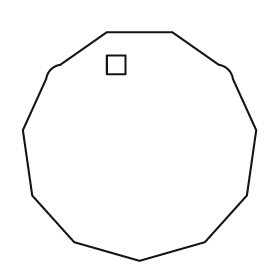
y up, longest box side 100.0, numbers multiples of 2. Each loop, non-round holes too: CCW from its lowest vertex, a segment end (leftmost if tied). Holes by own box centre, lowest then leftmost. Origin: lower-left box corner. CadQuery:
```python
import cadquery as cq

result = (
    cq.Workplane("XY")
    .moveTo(50.0, 0.0)
    .lineTo(78.0, 8.0)
    .lineTo(96.0, 28.0)
    .lineTo(100.0, 56.0)
    .lineTo(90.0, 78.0)
    .threePointArc((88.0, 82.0), (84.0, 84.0))
    .lineTo(64.0, 98.0)
    .lineTo(36.0, 98.0)
    .lineTo(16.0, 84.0)
    .threePointArc((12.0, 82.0), (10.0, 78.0))
    .lineTo(0.0, 56.0)
    .lineTo(4.0, 28.0)
    .lineTo(22.0, 8.0)
    .close()
    .moveTo(36.0, 80.0)
    .lineTo(44.0, 80.0)
    .lineTo(44.0, 88.0)
    .lineTo(36.0, 88.0)
    .close()
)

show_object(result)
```